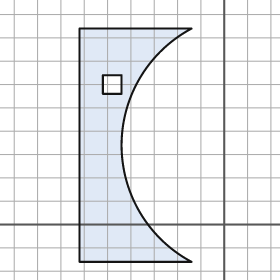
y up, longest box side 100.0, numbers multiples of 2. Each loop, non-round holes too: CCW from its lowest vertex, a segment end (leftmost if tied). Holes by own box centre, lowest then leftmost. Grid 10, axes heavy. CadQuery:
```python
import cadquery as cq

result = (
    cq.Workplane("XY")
    .moveTo(-62.0, -16.0)
    .lineTo(-14.0, -16.0)
    .threePointArc((-44.0, 34.0), (-14.0, 84.0))
    .lineTo(-62.0, 84.0)
    .close()
    .moveTo(-52.0, 56.0)
    .lineTo(-44.0, 56.0)
    .lineTo(-44.0, 64.0)
    .lineTo(-52.0, 64.0)
    .close()
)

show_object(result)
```